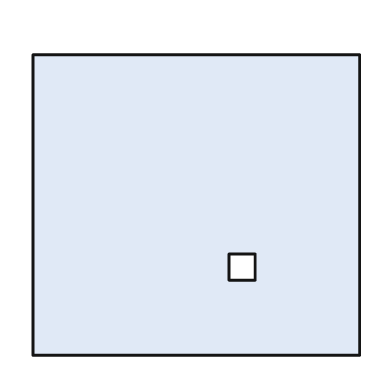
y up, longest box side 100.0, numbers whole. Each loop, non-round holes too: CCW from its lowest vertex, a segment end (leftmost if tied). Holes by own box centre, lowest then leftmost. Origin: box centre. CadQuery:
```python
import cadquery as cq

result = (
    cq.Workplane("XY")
    .moveTo(-50.0, -46.0)
    .lineTo(50.0, -46.0)
    .lineTo(50.0, 46.0)
    .lineTo(-50.0, 46.0)
    .close()
    .moveTo(10.0, -23.0)
    .lineTo(18.0, -23.0)
    .lineTo(18.0, -15.0)
    .lineTo(10.0, -15.0)
    .close()
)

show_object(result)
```